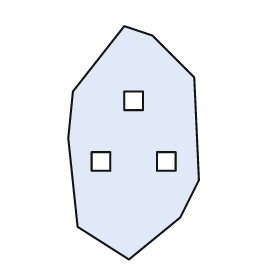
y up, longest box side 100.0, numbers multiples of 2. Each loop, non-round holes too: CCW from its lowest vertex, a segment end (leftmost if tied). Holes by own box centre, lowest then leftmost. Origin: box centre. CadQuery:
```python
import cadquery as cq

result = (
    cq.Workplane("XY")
    .moveTo(-2.0, -50.0)
    .lineTo(20.0, -32.0)
    .lineTo(28.0, -16.0)
    .lineTo(26.0, 28.0)
    .lineTo(8.0, 46.0)
    .lineTo(-4.0, 50.0)
    .lineTo(-26.0, 22.0)
    .lineTo(-28.0, 2.0)
    .lineTo(-24.0, -36.0)
    .close()
    .moveTo(-18.0, -12.0)
    .lineTo(-10.0, -12.0)
    .lineTo(-10.0, -4.0)
    .lineTo(-18.0, -4.0)
    .close()
    .moveTo(10.0, -12.0)
    .lineTo(18.0, -12.0)
    .lineTo(18.0, -4.0)
    .lineTo(10.0, -4.0)
    .close()
    .moveTo(-4.0, 14.0)
    .lineTo(4.0, 14.0)
    .lineTo(4.0, 22.0)
    .lineTo(-4.0, 22.0)
    .close()
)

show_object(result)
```